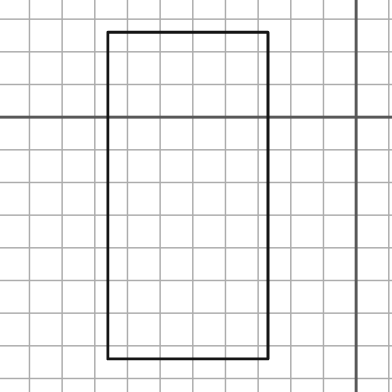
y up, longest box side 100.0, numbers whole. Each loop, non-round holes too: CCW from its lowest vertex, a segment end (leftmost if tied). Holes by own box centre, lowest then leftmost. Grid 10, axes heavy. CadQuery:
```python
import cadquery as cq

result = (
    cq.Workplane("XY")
    .moveTo(-76.0, -74.0)
    .lineTo(-27.0, -74.0)
    .lineTo(-27.0, 26.0)
    .lineTo(-76.0, 26.0)
    .close()
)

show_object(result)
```